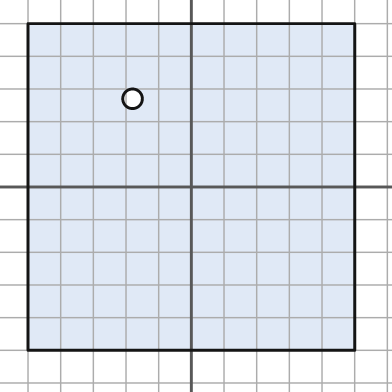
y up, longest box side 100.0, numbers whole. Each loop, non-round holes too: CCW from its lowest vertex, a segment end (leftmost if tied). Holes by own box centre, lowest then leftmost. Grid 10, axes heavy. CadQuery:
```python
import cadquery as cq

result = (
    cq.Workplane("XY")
    .moveTo(-50.0, -50.0)
    .lineTo(50.0, -50.0)
    .lineTo(50.0, 50.0)
    .lineTo(-50.0, 50.0)
    .close()
    .moveTo(-18.0, 27.0)
    .circle(3.0)
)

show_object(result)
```